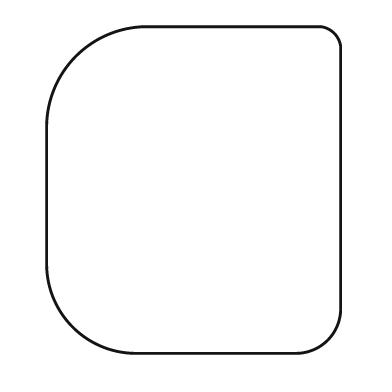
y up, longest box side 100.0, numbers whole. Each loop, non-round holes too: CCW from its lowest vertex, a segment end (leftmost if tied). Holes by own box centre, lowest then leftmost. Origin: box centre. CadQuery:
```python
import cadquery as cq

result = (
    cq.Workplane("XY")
    .moveTo(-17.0, -50.0)
    .lineTo(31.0, -50.0)
    .threePointArc((41.0, -46.0), (45.0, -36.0))
    .lineTo(45.0, 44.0)
    .threePointArc((43.0, 48.0), (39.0, 50.0))
    .lineTo(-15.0, 50.0)
    .threePointArc((-36.0, 41.0), (-45.0, 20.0))
    .lineTo(-45.0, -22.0)
    .threePointArc((-37.0, -42.0), (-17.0, -50.0))
    .close()
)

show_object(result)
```